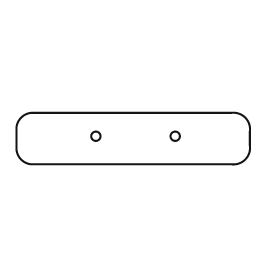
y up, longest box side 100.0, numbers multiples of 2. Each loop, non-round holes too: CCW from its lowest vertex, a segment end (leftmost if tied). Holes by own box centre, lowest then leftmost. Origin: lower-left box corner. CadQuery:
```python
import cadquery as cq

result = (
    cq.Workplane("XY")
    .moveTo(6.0, 0.0)
    .lineTo(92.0, 0.0)
    .threePointArc((98.0, 2.0), (100.0, 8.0))
    .lineTo(100.0, 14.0)
    .threePointArc((98.0, 20.0), (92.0, 22.0))
    .lineTo(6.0, 22.0)
    .threePointArc((2.0, 20.0), (0.0, 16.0))
    .lineTo(0.0, 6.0)
    .threePointArc((2.0, 2.0), (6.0, 0.0))
    .close()
    .moveTo(34.0, 12.0)
    .circle(2.0)
    .moveTo(68.0, 12.0)
    .circle(2.0)
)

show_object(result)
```